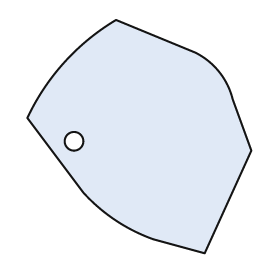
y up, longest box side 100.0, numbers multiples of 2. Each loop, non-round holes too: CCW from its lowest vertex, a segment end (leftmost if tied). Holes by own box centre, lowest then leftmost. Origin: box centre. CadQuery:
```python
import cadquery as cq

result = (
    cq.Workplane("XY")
    .moveTo(28.0, -50.0)
    .lineTo(48.0, -6.0)
    .lineTo(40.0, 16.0)
    .threePointArc((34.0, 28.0), (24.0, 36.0))
    .lineTo(-10.0, 50.0)
    .threePointArc((-32.0, 32.0), (-48.0, 8.0))
    .lineTo(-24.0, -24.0)
    .threePointArc((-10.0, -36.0), (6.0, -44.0))
    .close()
    .moveTo(-28.0, -2.0)
    .circle(4.0)
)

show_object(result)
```